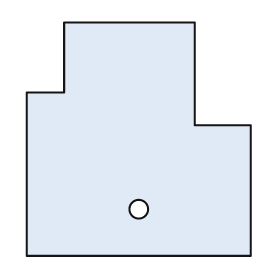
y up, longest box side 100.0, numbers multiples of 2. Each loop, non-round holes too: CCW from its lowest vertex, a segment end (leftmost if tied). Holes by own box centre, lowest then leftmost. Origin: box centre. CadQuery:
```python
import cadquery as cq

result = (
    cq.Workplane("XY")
    .moveTo(-48.0, -50.0)
    .lineTo(48.0, -50.0)
    .lineTo(48.0, 6.0)
    .lineTo(24.0, 6.0)
    .lineTo(24.0, 50.0)
    .lineTo(-32.0, 50.0)
    .lineTo(-32.0, 20.0)
    .lineTo(-48.0, 20.0)
    .close()
    .moveTo(0.0, -30.0)
    .circle(4.0)
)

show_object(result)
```